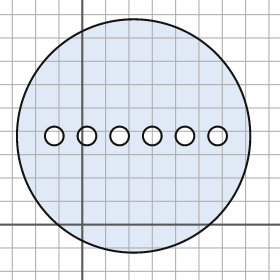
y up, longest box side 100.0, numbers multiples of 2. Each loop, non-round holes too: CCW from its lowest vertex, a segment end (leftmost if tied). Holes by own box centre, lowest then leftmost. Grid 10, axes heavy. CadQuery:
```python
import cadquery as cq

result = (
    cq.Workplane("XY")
    .moveTo(22.0, 38.0)
    .circle(50.0)
    .moveTo(-12.0, 38.0)
    .circle(4.0)
    .moveTo(2.0, 38.0)
    .circle(4.0)
    .moveTo(16.0, 38.0)
    .circle(4.0)
    .moveTo(30.0, 38.0)
    .circle(4.0)
    .moveTo(44.0, 38.0)
    .circle(4.0)
    .moveTo(58.0, 38.0)
    .circle(4.0)
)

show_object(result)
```